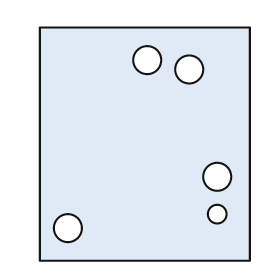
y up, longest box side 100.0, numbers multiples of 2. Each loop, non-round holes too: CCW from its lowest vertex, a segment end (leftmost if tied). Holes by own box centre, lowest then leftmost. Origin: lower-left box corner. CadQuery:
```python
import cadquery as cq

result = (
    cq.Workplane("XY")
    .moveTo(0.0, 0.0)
    .lineTo(90.0, 0.0)
    .lineTo(90.0, 100.0)
    .lineTo(0.0, 100.0)
    .close()
    .moveTo(12.0, 14.0)
    .circle(6.0)
    .moveTo(76.0, 20.0)
    .circle(4.0)
    .moveTo(76.0, 36.0)
    .circle(6.0)
    .moveTo(64.0, 82.0)
    .circle(6.0)
    .moveTo(46.0, 86.0)
    .circle(6.0)
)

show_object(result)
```